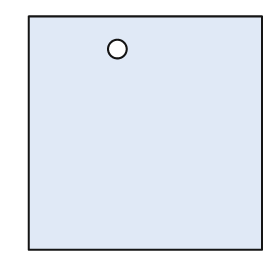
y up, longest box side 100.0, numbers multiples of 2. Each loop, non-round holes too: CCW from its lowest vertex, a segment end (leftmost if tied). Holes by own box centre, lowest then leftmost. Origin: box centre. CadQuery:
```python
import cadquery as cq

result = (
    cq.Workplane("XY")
    .moveTo(-50.0, -50.0)
    .lineTo(50.0, -50.0)
    .lineTo(50.0, 50.0)
    .lineTo(-50.0, 50.0)
    .close()
    .moveTo(-12.0, 36.0)
    .circle(4.0)
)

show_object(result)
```